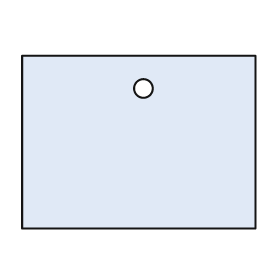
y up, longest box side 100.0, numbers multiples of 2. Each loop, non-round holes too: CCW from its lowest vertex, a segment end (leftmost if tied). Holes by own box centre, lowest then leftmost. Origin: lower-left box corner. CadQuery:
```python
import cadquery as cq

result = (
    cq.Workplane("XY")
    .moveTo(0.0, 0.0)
    .lineTo(100.0, 0.0)
    .lineTo(100.0, 74.0)
    .lineTo(0.0, 74.0)
    .close()
    .moveTo(52.0, 60.0)
    .circle(4.0)
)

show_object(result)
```